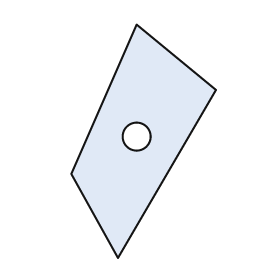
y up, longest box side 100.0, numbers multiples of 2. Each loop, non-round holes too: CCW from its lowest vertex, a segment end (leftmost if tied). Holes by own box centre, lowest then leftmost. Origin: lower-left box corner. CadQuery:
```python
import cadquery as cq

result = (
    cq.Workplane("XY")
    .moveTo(20.0, 0.0)
    .lineTo(62.0, 72.0)
    .lineTo(28.0, 100.0)
    .lineTo(0.0, 36.0)
    .close()
    .moveTo(28.0, 52.0)
    .circle(6.0)
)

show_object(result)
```